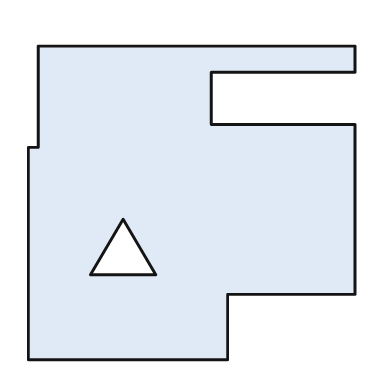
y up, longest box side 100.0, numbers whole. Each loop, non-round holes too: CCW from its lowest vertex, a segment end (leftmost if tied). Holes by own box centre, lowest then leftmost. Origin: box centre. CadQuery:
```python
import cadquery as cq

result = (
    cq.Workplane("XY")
    .moveTo(-50.0, -48.0)
    .lineTo(11.0, -48.0)
    .lineTo(11.0, -28.0)
    .lineTo(50.0, -28.0)
    .lineTo(50.0, 24.0)
    .lineTo(6.0, 24.0)
    .lineTo(6.0, 40.0)
    .lineTo(50.0, 40.0)
    .lineTo(50.0, 48.0)
    .lineTo(-47.0, 48.0)
    .lineTo(-47.0, 17.0)
    .lineTo(-50.0, 17.0)
    .close()
    .moveTo(-31.0, -22.0)
    .lineTo(-11.0, -22.0)
    .lineTo(-21.0, -5.0)
    .close()
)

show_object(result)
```